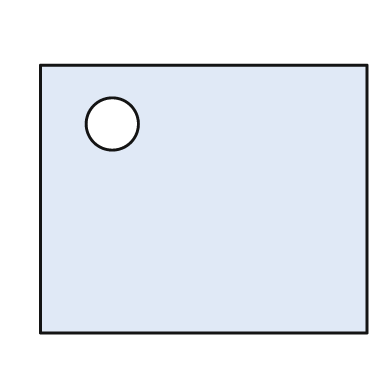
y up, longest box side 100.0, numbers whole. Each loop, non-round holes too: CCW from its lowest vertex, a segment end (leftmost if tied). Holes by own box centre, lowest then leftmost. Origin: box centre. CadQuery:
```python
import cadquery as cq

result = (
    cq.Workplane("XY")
    .moveTo(-50.0, -41.0)
    .lineTo(50.0, -41.0)
    .lineTo(50.0, 41.0)
    .lineTo(-50.0, 41.0)
    .close()
    .moveTo(-28.0, 23.0)
    .circle(8.0)
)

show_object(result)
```